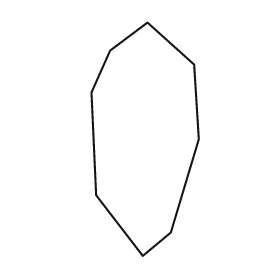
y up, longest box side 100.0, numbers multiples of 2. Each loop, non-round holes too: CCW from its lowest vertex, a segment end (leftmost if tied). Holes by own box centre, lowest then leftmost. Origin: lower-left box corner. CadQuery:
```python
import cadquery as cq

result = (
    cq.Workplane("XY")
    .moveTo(22.0, 0.0)
    .lineTo(34.0, 10.0)
    .lineTo(46.0, 50.0)
    .lineTo(44.0, 82.0)
    .lineTo(24.0, 100.0)
    .lineTo(8.0, 88.0)
    .lineTo(0.0, 70.0)
    .lineTo(2.0, 26.0)
    .close()
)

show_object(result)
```